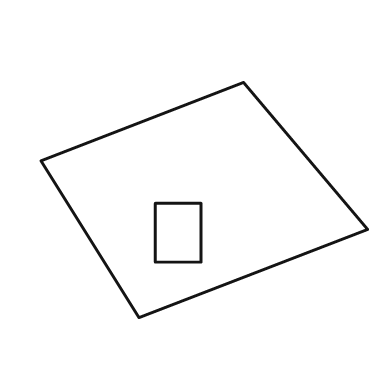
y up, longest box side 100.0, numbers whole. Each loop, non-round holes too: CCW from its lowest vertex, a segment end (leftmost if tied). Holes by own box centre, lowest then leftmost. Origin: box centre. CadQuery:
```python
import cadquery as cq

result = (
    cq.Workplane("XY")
    .moveTo(-20.0, -36.0)
    .lineTo(50.0, -9.0)
    .lineTo(12.0, 36.0)
    .lineTo(-50.0, 12.0)
    .close()
    .moveTo(-15.0, -19.0)
    .lineTo(-1.0, -19.0)
    .lineTo(-1.0, -1.0)
    .lineTo(-15.0, -1.0)
    .close()
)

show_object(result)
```